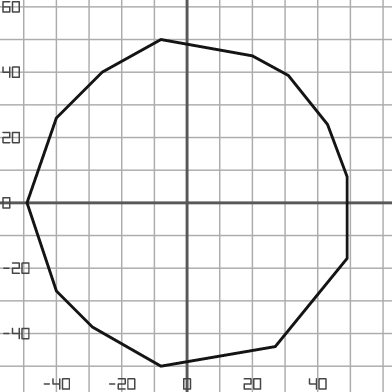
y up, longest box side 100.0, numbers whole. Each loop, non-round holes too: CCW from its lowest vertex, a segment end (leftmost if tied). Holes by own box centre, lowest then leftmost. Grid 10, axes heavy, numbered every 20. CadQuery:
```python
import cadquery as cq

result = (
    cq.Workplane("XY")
    .moveTo(-8.0, -50.0)
    .lineTo(27.0, -44.0)
    .lineTo(49.0, -17.0)
    .lineTo(49.0, 8.0)
    .lineTo(43.0, 24.0)
    .lineTo(31.0, 39.0)
    .lineTo(20.0, 45.0)
    .lineTo(-8.0, 50.0)
    .lineTo(-26.0, 40.0)
    .lineTo(-40.0, 26.0)
    .lineTo(-49.0, 0.0)
    .lineTo(-40.0, -27.0)
    .lineTo(-29.0, -38.0)
    .close()
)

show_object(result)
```